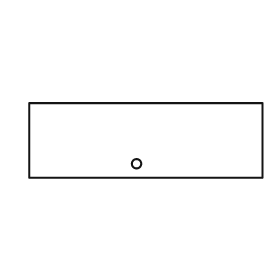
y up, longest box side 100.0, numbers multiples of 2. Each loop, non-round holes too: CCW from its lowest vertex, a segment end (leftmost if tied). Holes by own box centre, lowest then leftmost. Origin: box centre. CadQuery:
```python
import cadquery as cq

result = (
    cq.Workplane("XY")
    .moveTo(-50.0, -16.0)
    .lineTo(50.0, -16.0)
    .lineTo(50.0, 16.0)
    .lineTo(-50.0, 16.0)
    .close()
    .moveTo(-4.0, -10.0)
    .circle(2.0)
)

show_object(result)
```